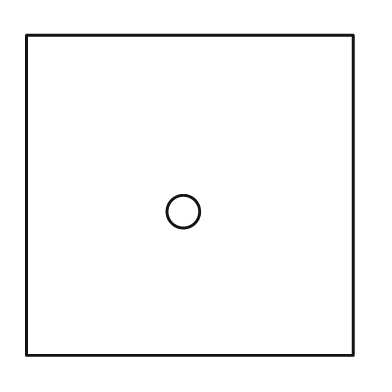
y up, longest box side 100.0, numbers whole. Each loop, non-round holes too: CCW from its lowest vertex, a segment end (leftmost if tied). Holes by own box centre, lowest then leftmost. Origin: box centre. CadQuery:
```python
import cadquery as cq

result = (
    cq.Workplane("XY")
    .moveTo(-50.0, -49.0)
    .lineTo(50.0, -49.0)
    .lineTo(50.0, 49.0)
    .lineTo(-50.0, 49.0)
    .close()
    .moveTo(-2.0, -5.0)
    .circle(5.0)
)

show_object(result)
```